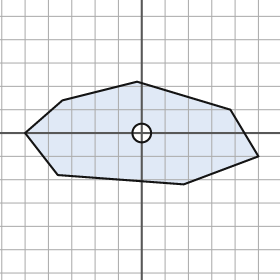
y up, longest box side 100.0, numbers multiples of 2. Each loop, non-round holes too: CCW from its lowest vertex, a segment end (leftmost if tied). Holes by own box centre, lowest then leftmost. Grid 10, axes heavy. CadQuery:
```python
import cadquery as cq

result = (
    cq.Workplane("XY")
    .moveTo(18.0, -22.0)
    .lineTo(50.0, -10.0)
    .lineTo(38.0, 10.0)
    .lineTo(-2.0, 22.0)
    .lineTo(-34.0, 14.0)
    .lineTo(-50.0, 0.0)
    .lineTo(-36.0, -18.0)
    .close()
    .moveTo(0.0, 0.0)
    .circle(4.0)
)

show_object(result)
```